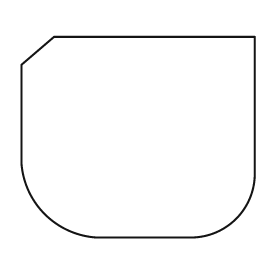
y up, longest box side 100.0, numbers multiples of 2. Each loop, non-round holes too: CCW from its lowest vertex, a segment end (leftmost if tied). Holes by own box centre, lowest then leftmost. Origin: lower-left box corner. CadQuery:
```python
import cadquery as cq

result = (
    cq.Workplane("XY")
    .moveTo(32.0, 0.0)
    .lineTo(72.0, 0.0)
    .threePointArc((92.0, 8.0), (100.0, 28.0))
    .lineTo(100.0, 86.0)
    .lineTo(14.0, 86.0)
    .lineTo(0.0, 74.0)
    .lineTo(0.0, 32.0)
    .threePointArc((10.0, 10.0), (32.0, 0.0))
    .close()
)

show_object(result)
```